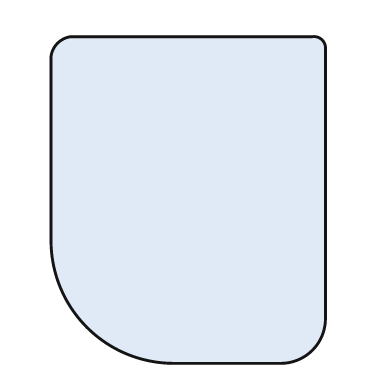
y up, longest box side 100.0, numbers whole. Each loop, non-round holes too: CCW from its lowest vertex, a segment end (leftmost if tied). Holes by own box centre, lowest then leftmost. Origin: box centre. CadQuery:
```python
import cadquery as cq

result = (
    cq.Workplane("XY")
    .moveTo(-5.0, -50.0)
    .lineTo(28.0, -50.0)
    .threePointArc((38.0, -46.0), (42.0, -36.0))
    .lineTo(42.0, 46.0)
    .threePointArc((41.0, 49.0), (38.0, 50.0))
    .lineTo(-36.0, 50.0)
    .threePointArc((-40.0, 48.0), (-42.0, 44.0))
    .lineTo(-42.0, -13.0)
    .threePointArc((-31.0, -39.0), (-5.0, -50.0))
    .close()
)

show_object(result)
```